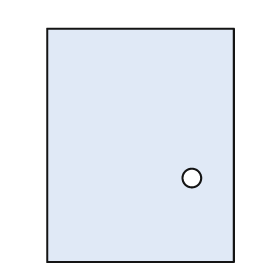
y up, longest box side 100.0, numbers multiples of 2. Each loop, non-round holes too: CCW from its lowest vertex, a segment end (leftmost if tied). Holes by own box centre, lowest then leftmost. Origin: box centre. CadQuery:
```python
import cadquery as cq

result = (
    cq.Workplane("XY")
    .moveTo(-40.0, -50.0)
    .lineTo(40.0, -50.0)
    .lineTo(40.0, 50.0)
    .lineTo(-40.0, 50.0)
    .close()
    .moveTo(22.0, -14.0)
    .circle(4.0)
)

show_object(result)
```